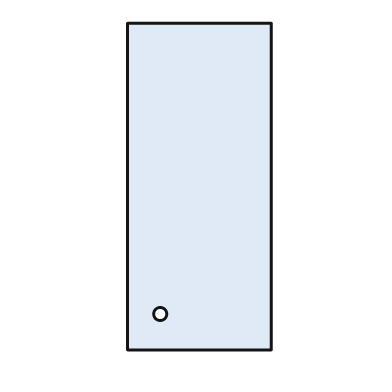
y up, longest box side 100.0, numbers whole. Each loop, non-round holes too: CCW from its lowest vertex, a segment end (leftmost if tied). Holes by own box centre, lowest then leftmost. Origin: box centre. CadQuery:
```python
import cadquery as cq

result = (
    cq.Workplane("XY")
    .moveTo(-22.0, -50.0)
    .lineTo(22.0, -50.0)
    .lineTo(22.0, 50.0)
    .lineTo(-22.0, 50.0)
    .close()
    .moveTo(-12.0, -39.0)
    .circle(2.0)
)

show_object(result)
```